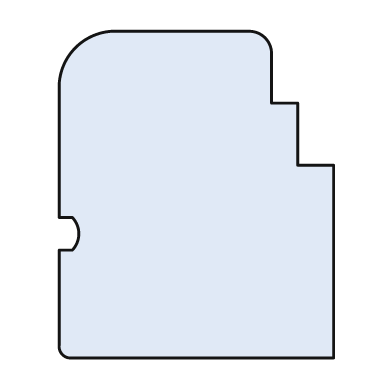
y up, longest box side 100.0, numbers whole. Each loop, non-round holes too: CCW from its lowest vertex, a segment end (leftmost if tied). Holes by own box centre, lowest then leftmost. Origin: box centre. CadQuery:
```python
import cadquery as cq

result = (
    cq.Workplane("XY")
    .moveTo(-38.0, -50.0)
    .lineTo(42.0, -50.0)
    .lineTo(42.0, 9.0)
    .lineTo(31.0, 9.0)
    .lineTo(31.0, 28.0)
    .lineTo(23.0, 28.0)
    .lineTo(23.0, 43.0)
    .threePointArc((21.0, 48.0), (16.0, 50.0))
    .lineTo(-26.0, 50.0)
    .threePointArc((-37.0, 45.0), (-42.0, 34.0))
    .lineTo(-42.0, -7.0)
    .lineTo(-38.0, -7.0)
    .threePointArc((-36.0, -12.0), (-38.0, -17.0))
    .lineTo(-42.0, -17.0)
    .lineTo(-42.0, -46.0)
    .threePointArc((-41.0, -49.0), (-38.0, -50.0))
    .close()
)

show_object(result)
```